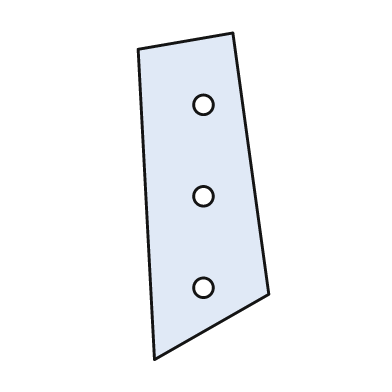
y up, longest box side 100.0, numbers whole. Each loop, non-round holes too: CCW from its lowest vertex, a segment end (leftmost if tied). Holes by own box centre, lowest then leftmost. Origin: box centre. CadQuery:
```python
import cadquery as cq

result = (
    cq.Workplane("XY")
    .moveTo(-15.0, -50.0)
    .lineTo(20.0, -30.0)
    .lineTo(9.0, 50.0)
    .lineTo(-20.0, 45.0)
    .close()
    .moveTo(0.0, -28.0)
    .circle(3.0)
    .moveTo(0.0, 0.0)
    .circle(3.0)
    .moveTo(0.0, 28.0)
    .circle(3.0)
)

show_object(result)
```